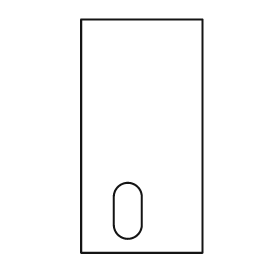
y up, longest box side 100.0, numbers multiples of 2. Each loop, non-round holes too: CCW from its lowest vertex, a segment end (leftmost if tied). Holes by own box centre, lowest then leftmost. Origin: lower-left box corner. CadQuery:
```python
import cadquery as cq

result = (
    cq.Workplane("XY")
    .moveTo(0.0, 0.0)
    .lineTo(52.0, 0.0)
    .lineTo(52.0, 100.0)
    .lineTo(0.0, 100.0)
    .close()
    .moveTo(14.0, 12.0)
    .threePointArc((20.0, 6.0), (26.0, 12.0))
    .lineTo(26.0, 24.0)
    .threePointArc((20.0, 30.0), (14.0, 24.0))
    .close()
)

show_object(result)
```